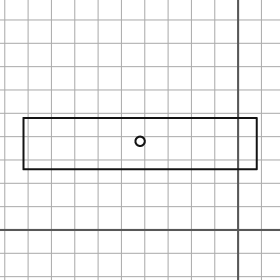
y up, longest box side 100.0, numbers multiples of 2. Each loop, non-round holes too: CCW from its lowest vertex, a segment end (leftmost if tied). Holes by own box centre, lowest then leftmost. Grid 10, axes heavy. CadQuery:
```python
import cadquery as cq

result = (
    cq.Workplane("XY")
    .moveTo(-92.0, 26.0)
    .lineTo(8.0, 26.0)
    .lineTo(8.0, 48.0)
    .lineTo(-92.0, 48.0)
    .close()
    .moveTo(-42.0, 38.0)
    .circle(2.0)
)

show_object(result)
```